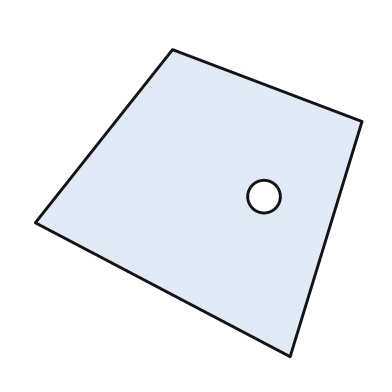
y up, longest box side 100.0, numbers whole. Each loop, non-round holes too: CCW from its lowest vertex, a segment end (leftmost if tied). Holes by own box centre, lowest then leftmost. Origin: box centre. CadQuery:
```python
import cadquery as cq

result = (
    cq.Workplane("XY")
    .moveTo(28.0, -47.0)
    .lineTo(50.0, 25.0)
    .lineTo(-8.0, 47.0)
    .lineTo(-50.0, -6.0)
    .close()
    .moveTo(20.0, 2.0)
    .circle(5.0)
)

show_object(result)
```